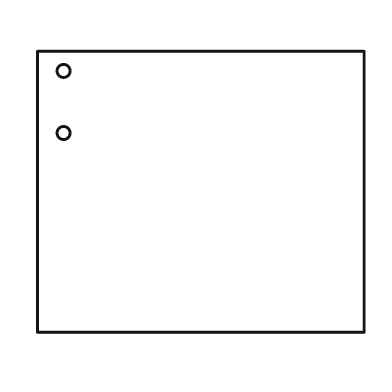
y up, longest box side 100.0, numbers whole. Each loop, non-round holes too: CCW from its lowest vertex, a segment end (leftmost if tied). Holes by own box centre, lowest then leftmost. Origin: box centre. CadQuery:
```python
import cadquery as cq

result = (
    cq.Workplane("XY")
    .moveTo(-50.0, -43.0)
    .lineTo(50.0, -43.0)
    .lineTo(50.0, 43.0)
    .lineTo(-50.0, 43.0)
    .close()
    .moveTo(-42.0, 18.0)
    .circle(2.0)
    .moveTo(-42.0, 37.0)
    .circle(2.0)
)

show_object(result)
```